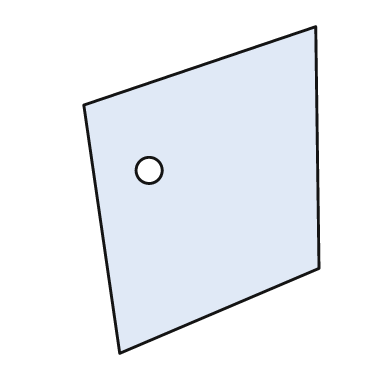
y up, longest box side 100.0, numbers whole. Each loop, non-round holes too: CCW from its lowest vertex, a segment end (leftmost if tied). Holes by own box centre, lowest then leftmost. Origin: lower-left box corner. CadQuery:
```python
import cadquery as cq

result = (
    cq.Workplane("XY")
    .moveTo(11.0, 0.0)
    .lineTo(72.0, 26.0)
    .lineTo(71.0, 100.0)
    .lineTo(0.0, 76.0)
    .close()
    .moveTo(20.0, 56.0)
    .circle(4.0)
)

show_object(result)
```